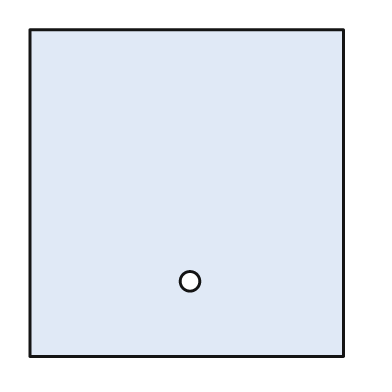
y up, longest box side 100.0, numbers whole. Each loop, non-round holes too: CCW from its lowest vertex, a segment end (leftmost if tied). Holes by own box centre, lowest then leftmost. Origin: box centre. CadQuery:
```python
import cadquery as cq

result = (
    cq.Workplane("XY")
    .moveTo(-48.0, -50.0)
    .lineTo(48.0, -50.0)
    .lineTo(48.0, 50.0)
    .lineTo(-48.0, 50.0)
    .close()
    .moveTo(1.0, -27.0)
    .circle(3.0)
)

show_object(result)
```